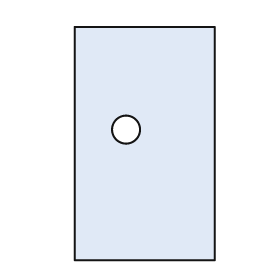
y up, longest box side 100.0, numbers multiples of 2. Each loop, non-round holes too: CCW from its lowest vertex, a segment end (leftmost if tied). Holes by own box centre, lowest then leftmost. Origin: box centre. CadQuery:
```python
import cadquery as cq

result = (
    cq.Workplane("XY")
    .moveTo(-30.0, -50.0)
    .lineTo(30.0, -50.0)
    .lineTo(30.0, 50.0)
    .lineTo(-30.0, 50.0)
    .close()
    .moveTo(-8.0, 6.0)
    .circle(6.0)
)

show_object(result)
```